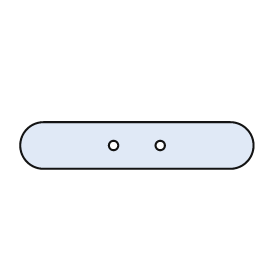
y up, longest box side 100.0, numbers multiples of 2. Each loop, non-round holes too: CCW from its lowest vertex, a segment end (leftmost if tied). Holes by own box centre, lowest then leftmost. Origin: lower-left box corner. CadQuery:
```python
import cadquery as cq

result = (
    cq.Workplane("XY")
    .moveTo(10.0, 0.0)
    .lineTo(90.0, 0.0)
    .threePointArc((100.0, 10.0), (90.0, 20.0))
    .lineTo(10.0, 20.0)
    .threePointArc((0.0, 10.0), (10.0, 0.0))
    .close()
    .moveTo(40.0, 10.0)
    .circle(2.0)
    .moveTo(60.0, 10.0)
    .circle(2.0)
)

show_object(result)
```